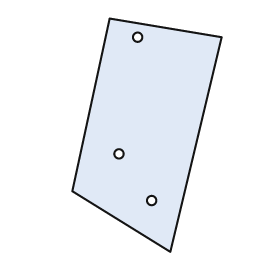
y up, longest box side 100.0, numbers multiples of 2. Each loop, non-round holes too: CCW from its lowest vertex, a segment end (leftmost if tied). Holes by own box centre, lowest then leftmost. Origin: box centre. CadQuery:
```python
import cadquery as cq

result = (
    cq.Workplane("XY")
    .moveTo(10.0, -50.0)
    .lineTo(32.0, 42.0)
    .lineTo(-16.0, 50.0)
    .lineTo(-32.0, -24.0)
    .close()
    .moveTo(2.0, -28.0)
    .circle(2.0)
    .moveTo(-12.0, -8.0)
    .circle(2.0)
    .moveTo(-4.0, 42.0)
    .circle(2.0)
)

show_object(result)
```